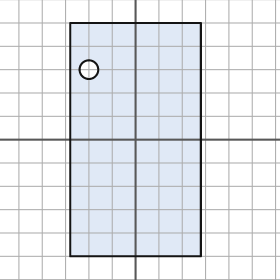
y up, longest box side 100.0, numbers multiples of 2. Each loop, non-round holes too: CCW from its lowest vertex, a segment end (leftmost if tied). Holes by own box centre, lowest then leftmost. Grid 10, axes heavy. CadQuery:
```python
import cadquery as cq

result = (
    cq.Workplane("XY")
    .moveTo(-28.0, -50.0)
    .lineTo(28.0, -50.0)
    .lineTo(28.0, 50.0)
    .lineTo(-28.0, 50.0)
    .close()
    .moveTo(-20.0, 30.0)
    .circle(4.0)
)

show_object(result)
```